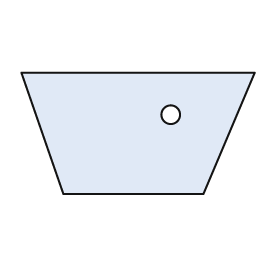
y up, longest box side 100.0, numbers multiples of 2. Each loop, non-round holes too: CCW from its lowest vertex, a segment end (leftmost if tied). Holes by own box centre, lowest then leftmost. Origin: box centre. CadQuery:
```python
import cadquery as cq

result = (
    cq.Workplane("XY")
    .moveTo(-32.0, -26.0)
    .lineTo(28.0, -26.0)
    .lineTo(50.0, 26.0)
    .lineTo(-50.0, 26.0)
    .close()
    .moveTo(14.0, 8.0)
    .circle(4.0)
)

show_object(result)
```